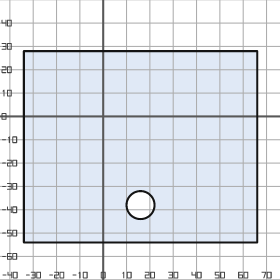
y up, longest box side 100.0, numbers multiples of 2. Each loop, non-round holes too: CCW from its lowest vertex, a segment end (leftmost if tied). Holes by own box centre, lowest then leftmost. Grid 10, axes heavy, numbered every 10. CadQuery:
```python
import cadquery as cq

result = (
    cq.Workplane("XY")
    .moveTo(-34.0, -54.0)
    .lineTo(66.0, -54.0)
    .lineTo(66.0, 28.0)
    .lineTo(-34.0, 28.0)
    .close()
    .moveTo(16.0, -38.0)
    .circle(6.0)
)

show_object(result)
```